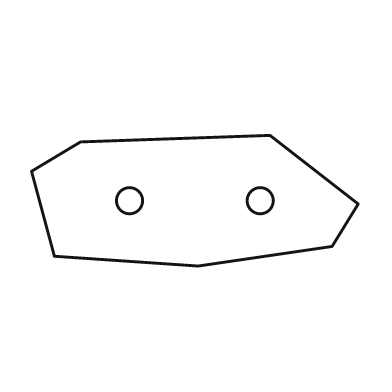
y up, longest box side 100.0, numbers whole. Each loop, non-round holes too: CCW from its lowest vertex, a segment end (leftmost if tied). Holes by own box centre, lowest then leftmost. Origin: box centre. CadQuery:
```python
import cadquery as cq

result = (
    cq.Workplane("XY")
    .moveTo(1.0, -20.0)
    .lineTo(42.0, -14.0)
    .lineTo(50.0, -1.0)
    .lineTo(23.0, 20.0)
    .lineTo(-35.0, 18.0)
    .lineTo(-50.0, 9.0)
    .lineTo(-43.0, -17.0)
    .close()
    .moveTo(-20.0, 0.0)
    .circle(4.0)
    .moveTo(20.0, 0.0)
    .circle(4.0)
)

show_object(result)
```